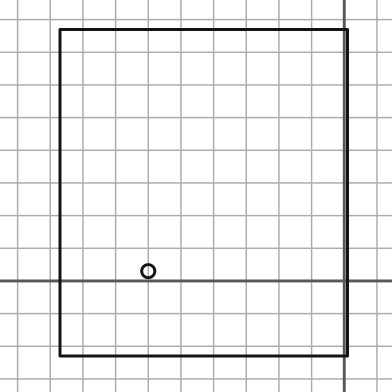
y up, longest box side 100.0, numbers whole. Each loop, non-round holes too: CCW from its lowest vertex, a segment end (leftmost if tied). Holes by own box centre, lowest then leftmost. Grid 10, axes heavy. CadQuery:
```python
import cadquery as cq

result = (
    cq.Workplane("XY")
    .moveTo(-87.0, -23.0)
    .lineTo(1.0, -23.0)
    .lineTo(1.0, 77.0)
    .lineTo(-87.0, 77.0)
    .close()
    .moveTo(-60.0, 3.0)
    .circle(2.0)
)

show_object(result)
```